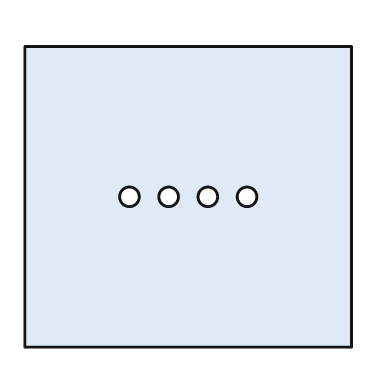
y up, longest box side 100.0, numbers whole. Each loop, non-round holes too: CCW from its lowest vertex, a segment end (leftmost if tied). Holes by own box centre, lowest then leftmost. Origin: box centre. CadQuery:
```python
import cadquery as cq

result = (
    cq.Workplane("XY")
    .moveTo(-50.0, -46.0)
    .lineTo(50.0, -46.0)
    .lineTo(50.0, 46.0)
    .lineTo(-50.0, 46.0)
    .close()
    .moveTo(-18.0, 0.0)
    .circle(3.0)
    .moveTo(-6.0, 0.0)
    .circle(3.0)
    .moveTo(6.0, 0.0)
    .circle(3.0)
    .moveTo(18.0, 0.0)
    .circle(3.0)
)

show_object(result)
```